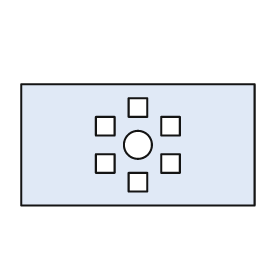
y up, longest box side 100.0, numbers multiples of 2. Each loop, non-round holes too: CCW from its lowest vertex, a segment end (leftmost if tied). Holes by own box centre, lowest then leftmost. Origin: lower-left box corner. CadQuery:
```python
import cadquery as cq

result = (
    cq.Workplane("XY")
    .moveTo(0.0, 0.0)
    .lineTo(100.0, 0.0)
    .lineTo(100.0, 52.0)
    .lineTo(0.0, 52.0)
    .close()
    .moveTo(46.0, 6.0)
    .lineTo(54.0, 6.0)
    .lineTo(54.0, 14.0)
    .lineTo(46.0, 14.0)
    .close()
    .moveTo(32.0, 14.0)
    .lineTo(40.0, 14.0)
    .lineTo(40.0, 22.0)
    .lineTo(32.0, 22.0)
    .close()
    .moveTo(60.0, 14.0)
    .lineTo(68.0, 14.0)
    .lineTo(68.0, 22.0)
    .lineTo(60.0, 22.0)
    .close()
    .moveTo(50.0, 26.0)
    .circle(6.0)
    .moveTo(32.0, 30.0)
    .lineTo(40.0, 30.0)
    .lineTo(40.0, 38.0)
    .lineTo(32.0, 38.0)
    .close()
    .moveTo(60.0, 30.0)
    .lineTo(68.0, 30.0)
    .lineTo(68.0, 38.0)
    .lineTo(60.0, 38.0)
    .close()
    .moveTo(46.0, 38.0)
    .lineTo(54.0, 38.0)
    .lineTo(54.0, 46.0)
    .lineTo(46.0, 46.0)
    .close()
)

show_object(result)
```